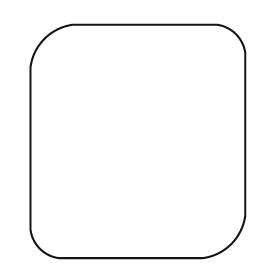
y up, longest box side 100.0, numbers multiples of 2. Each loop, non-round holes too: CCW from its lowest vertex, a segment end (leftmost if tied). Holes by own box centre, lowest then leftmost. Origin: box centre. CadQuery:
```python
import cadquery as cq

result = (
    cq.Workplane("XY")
    .moveTo(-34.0, -50.0)
    .lineTo(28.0, -50.0)
    .threePointArc((40.0, -44.0), (46.0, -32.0))
    .lineTo(46.0, 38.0)
    .threePointArc((42.0, 46.0), (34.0, 50.0))
    .lineTo(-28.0, 50.0)
    .threePointArc((-40.0, 44.0), (-46.0, 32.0))
    .lineTo(-46.0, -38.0)
    .threePointArc((-42.0, -46.0), (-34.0, -50.0))
    .close()
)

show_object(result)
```